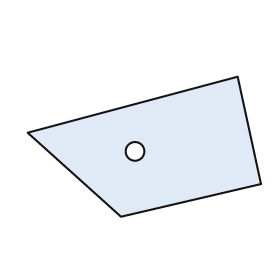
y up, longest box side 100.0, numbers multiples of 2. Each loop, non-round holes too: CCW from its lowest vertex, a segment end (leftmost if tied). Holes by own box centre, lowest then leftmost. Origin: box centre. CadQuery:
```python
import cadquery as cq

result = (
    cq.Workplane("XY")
    .moveTo(-10.0, -30.0)
    .lineTo(50.0, -16.0)
    .lineTo(40.0, 30.0)
    .lineTo(-50.0, 6.0)
    .close()
    .moveTo(-4.0, -2.0)
    .circle(4.0)
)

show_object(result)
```